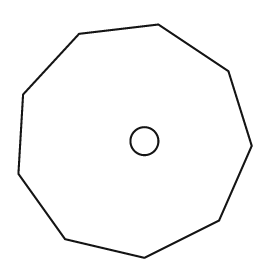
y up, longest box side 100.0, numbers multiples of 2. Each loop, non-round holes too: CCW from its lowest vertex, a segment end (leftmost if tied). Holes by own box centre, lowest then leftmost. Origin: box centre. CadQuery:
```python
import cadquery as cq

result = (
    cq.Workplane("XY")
    .moveTo(4.0, -50.0)
    .lineTo(36.0, -34.0)
    .lineTo(50.0, -2.0)
    .lineTo(40.0, 30.0)
    .lineTo(10.0, 50.0)
    .lineTo(-24.0, 46.0)
    .lineTo(-48.0, 20.0)
    .lineTo(-50.0, -14.0)
    .lineTo(-30.0, -42.0)
    .close()
    .moveTo(4.0, 0.0)
    .circle(6.0)
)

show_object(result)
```